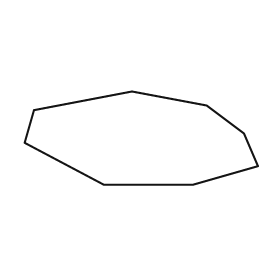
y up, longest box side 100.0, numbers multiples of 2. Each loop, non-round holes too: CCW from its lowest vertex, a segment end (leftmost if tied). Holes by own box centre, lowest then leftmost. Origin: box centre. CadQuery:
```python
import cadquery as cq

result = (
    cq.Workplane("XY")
    .moveTo(-16.0, -20.0)
    .lineTo(22.0, -20.0)
    .lineTo(50.0, -12.0)
    .lineTo(44.0, 2.0)
    .lineTo(28.0, 14.0)
    .lineTo(-4.0, 20.0)
    .lineTo(-46.0, 12.0)
    .lineTo(-50.0, -2.0)
    .close()
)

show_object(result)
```